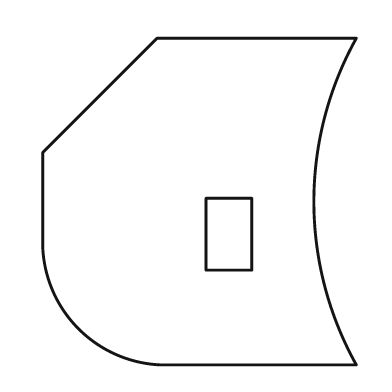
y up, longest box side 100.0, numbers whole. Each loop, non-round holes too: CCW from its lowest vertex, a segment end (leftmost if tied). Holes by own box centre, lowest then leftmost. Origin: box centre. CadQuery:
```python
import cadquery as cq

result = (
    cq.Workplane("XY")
    .moveTo(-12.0, -50.0)
    .lineTo(48.0, -50.0)
    .threePointArc((35.0, 0.0), (48.0, 50.0))
    .lineTo(-13.0, 50.0)
    .lineTo(-48.0, 15.0)
    .lineTo(-48.0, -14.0)
    .threePointArc((-37.0, -39.0), (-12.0, -50.0))
    .close()
    .moveTo(2.0, -21.0)
    .lineTo(16.0, -21.0)
    .lineTo(16.0, 1.0)
    .lineTo(2.0, 1.0)
    .close()
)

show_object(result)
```